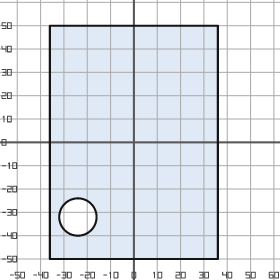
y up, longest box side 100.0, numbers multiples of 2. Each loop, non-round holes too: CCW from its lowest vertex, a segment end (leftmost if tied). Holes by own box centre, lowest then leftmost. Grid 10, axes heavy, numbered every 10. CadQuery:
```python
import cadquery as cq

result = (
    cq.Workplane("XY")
    .moveTo(-36.0, -50.0)
    .lineTo(36.0, -50.0)
    .lineTo(36.0, 50.0)
    .lineTo(-36.0, 50.0)
    .close()
    .moveTo(-24.0, -32.0)
    .circle(8.0)
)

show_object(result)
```